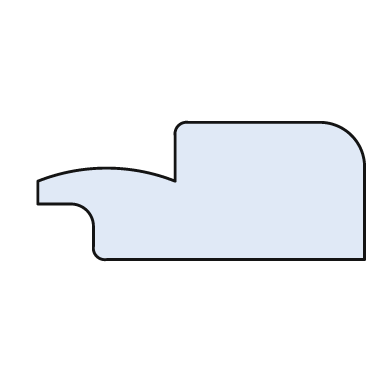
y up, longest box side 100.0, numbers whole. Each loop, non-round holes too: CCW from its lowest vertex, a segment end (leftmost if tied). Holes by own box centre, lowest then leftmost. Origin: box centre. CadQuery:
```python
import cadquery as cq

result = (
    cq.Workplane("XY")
    .moveTo(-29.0, -21.0)
    .lineTo(50.0, -21.0)
    .lineTo(50.0, 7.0)
    .threePointArc((46.0, 17.0), (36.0, 21.0))
    .lineTo(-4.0, 21.0)
    .threePointArc((-7.0, 20.0), (-8.0, 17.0))
    .lineTo(-8.0, 3.0)
    .threePointArc((-29.0, 7.0), (-50.0, 3.0))
    .lineTo(-50.0, -4.0)
    .lineTo(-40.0, -4.0)
    .threePointArc((-35.0, -6.0), (-33.0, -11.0))
    .lineTo(-33.0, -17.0)
    .threePointArc((-32.0, -20.0), (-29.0, -21.0))
    .close()
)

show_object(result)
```